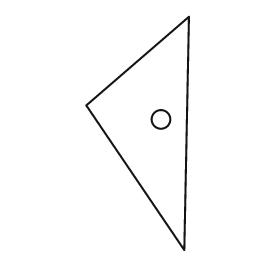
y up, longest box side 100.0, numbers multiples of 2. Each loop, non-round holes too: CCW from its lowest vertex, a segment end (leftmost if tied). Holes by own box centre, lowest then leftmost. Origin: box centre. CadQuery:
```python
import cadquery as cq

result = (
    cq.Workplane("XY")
    .moveTo(20.0, -50.0)
    .lineTo(22.0, 50.0)
    .lineTo(-22.0, 12.0)
    .close()
    .moveTo(10.0, 6.0)
    .circle(4.0)
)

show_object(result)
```